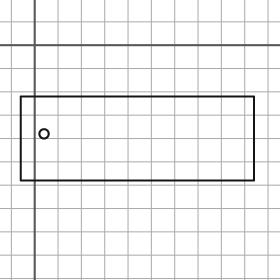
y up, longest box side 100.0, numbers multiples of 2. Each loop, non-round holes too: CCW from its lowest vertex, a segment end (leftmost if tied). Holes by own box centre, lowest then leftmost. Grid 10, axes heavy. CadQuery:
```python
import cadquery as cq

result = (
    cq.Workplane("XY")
    .moveTo(-6.0, -58.0)
    .lineTo(94.0, -58.0)
    .lineTo(94.0, -22.0)
    .lineTo(-6.0, -22.0)
    .close()
    .moveTo(4.0, -38.0)
    .circle(2.0)
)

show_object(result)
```